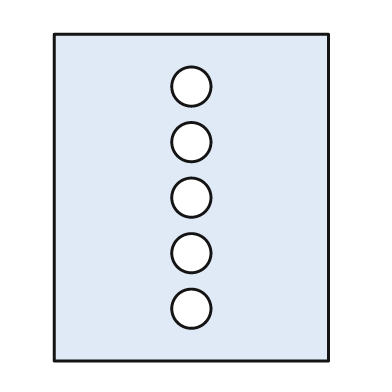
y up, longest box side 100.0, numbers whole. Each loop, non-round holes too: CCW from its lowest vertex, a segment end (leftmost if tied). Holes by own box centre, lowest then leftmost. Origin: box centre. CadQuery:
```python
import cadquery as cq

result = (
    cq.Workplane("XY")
    .moveTo(-42.0, -50.0)
    .lineTo(42.0, -50.0)
    .lineTo(42.0, 50.0)
    .lineTo(-42.0, 50.0)
    .close()
    .moveTo(0.0, -34.0)
    .circle(6.0)
    .moveTo(0.0, -17.0)
    .circle(6.0)
    .moveTo(0.0, 0.0)
    .circle(6.0)
    .moveTo(0.0, 17.0)
    .circle(6.0)
    .moveTo(0.0, 34.0)
    .circle(6.0)
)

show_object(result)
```